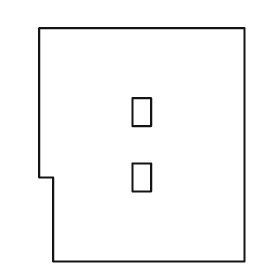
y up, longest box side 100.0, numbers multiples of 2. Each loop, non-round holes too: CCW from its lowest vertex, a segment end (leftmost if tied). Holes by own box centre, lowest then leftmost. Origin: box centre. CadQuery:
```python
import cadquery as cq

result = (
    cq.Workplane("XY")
    .moveTo(-38.0, -50.0)
    .lineTo(44.0, -50.0)
    .lineTo(44.0, 50.0)
    .lineTo(-44.0, 50.0)
    .lineTo(-44.0, -14.0)
    .lineTo(-38.0, -14.0)
    .close()
    .moveTo(-4.0, -20.0)
    .lineTo(4.0, -20.0)
    .lineTo(4.0, -8.0)
    .lineTo(-4.0, -8.0)
    .close()
    .moveTo(-4.0, 8.0)
    .lineTo(4.0, 8.0)
    .lineTo(4.0, 20.0)
    .lineTo(-4.0, 20.0)
    .close()
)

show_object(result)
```